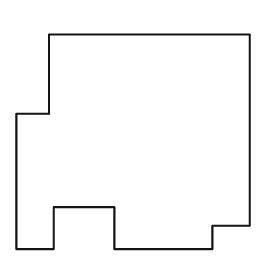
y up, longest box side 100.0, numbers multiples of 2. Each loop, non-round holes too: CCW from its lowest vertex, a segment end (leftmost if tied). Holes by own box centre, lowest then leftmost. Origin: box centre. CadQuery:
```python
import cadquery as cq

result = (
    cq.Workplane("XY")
    .moveTo(-50.0, -46.0)
    .lineTo(-34.0, -46.0)
    .lineTo(-34.0, -28.0)
    .lineTo(-8.0, -28.0)
    .lineTo(-8.0, -46.0)
    .lineTo(34.0, -46.0)
    .lineTo(34.0, -36.0)
    .lineTo(50.0, -36.0)
    .lineTo(50.0, 46.0)
    .lineTo(-36.0, 46.0)
    .lineTo(-36.0, 12.0)
    .lineTo(-50.0, 12.0)
    .close()
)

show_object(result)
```